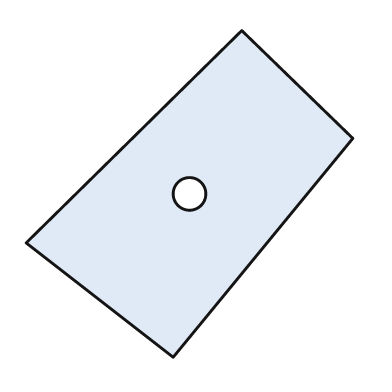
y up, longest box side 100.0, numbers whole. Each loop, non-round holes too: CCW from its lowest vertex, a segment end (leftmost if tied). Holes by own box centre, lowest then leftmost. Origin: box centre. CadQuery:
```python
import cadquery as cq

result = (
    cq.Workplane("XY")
    .moveTo(-5.0, -50.0)
    .lineTo(50.0, 17.0)
    .lineTo(16.0, 50.0)
    .lineTo(-50.0, -15.0)
    .close()
    .moveTo(0.0, 0.0)
    .circle(5.0)
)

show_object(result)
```